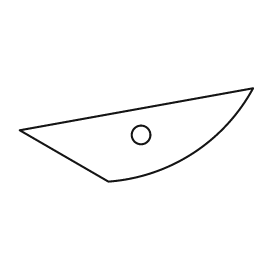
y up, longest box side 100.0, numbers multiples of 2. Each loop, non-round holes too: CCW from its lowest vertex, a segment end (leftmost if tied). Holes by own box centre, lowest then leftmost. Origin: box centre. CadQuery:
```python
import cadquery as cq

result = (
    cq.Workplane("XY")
    .moveTo(-12.0, -20.0)
    .threePointArc((24.0, -8.0), (50.0, 20.0))
    .lineTo(-50.0, 2.0)
    .close()
    .moveTo(2.0, 0.0)
    .circle(4.0)
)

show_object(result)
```